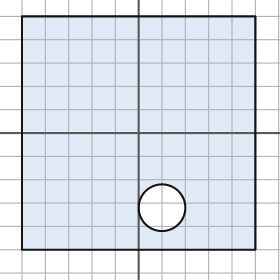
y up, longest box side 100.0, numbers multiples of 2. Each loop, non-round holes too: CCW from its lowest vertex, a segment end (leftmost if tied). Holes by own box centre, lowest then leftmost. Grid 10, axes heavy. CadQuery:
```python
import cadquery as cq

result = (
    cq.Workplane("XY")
    .moveTo(-50.0, -50.0)
    .lineTo(50.0, -50.0)
    .lineTo(50.0, 50.0)
    .lineTo(-50.0, 50.0)
    .close()
    .moveTo(10.0, -32.0)
    .circle(10.0)
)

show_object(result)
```